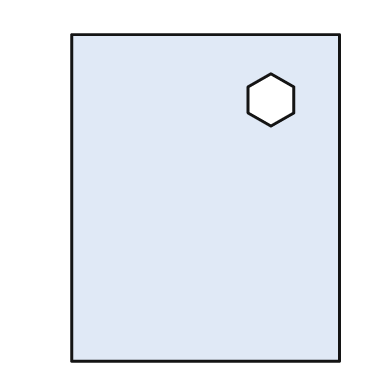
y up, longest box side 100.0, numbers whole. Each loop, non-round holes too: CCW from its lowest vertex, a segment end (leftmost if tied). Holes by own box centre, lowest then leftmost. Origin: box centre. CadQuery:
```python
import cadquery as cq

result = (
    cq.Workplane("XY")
    .moveTo(-41.0, -50.0)
    .lineTo(41.0, -50.0)
    .lineTo(41.0, 50.0)
    .lineTo(-41.0, 50.0)
    .close()
    .moveTo(20.0, 22.0)
    .lineTo(27.0, 26.0)
    .lineTo(27.0, 34.0)
    .lineTo(20.0, 38.0)
    .lineTo(13.0, 34.0)
    .lineTo(13.0, 26.0)
    .close()
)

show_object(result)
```